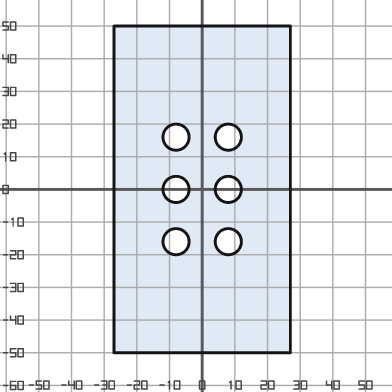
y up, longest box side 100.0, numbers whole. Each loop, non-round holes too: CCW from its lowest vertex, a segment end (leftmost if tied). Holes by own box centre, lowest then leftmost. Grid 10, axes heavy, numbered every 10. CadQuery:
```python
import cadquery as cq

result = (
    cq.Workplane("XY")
    .moveTo(-27.0, -50.0)
    .lineTo(27.0, -50.0)
    .lineTo(27.0, 50.0)
    .lineTo(-27.0, 50.0)
    .close()
    .moveTo(-8.0, -16.0)
    .circle(4.0)
    .moveTo(8.0, -16.0)
    .circle(4.0)
    .moveTo(-8.0, 0.0)
    .circle(4.0)
    .moveTo(8.0, 0.0)
    .circle(4.0)
    .moveTo(-8.0, 16.0)
    .circle(4.0)
    .moveTo(8.0, 16.0)
    .circle(4.0)
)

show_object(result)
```